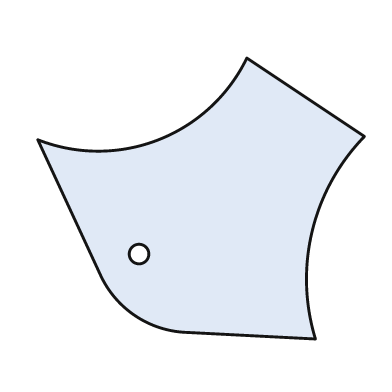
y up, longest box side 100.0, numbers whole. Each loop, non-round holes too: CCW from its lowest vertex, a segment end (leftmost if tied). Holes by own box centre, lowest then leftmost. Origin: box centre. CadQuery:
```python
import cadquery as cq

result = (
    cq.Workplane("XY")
    .moveTo(35.0, -43.0)
    .threePointArc((34.0, -10.0), (50.0, 19.0))
    .lineTo(14.0, 43.0)
    .threePointArc((-13.0, 18.0), (-50.0, 18.0))
    .lineTo(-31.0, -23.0)
    .threePointArc((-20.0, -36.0), (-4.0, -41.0))
    .close()
    .moveTo(-19.0, -17.0)
    .circle(3.0)
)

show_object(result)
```